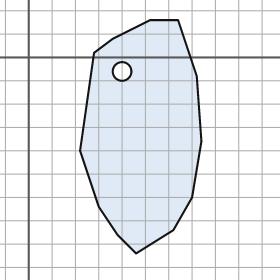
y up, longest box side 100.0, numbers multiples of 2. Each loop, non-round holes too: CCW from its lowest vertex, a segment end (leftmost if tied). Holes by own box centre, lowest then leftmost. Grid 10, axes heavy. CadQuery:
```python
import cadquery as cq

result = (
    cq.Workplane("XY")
    .moveTo(46.0, -84.0)
    .lineTo(62.0, -74.0)
    .lineTo(70.0, -60.0)
    .lineTo(74.0, -36.0)
    .lineTo(72.0, -8.0)
    .lineTo(64.0, 16.0)
    .lineTo(52.0, 16.0)
    .lineTo(36.0, 8.0)
    .lineTo(28.0, 2.0)
    .lineTo(22.0, -40.0)
    .lineTo(30.0, -64.0)
    .lineTo(38.0, -76.0)
    .close()
    .moveTo(40.0, -6.0)
    .circle(4.0)
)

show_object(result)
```